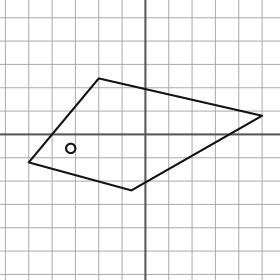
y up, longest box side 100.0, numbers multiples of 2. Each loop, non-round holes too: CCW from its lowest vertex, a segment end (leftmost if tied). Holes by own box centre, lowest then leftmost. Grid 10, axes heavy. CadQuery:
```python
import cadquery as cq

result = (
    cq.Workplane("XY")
    .moveTo(-6.0, -24.0)
    .lineTo(50.0, 8.0)
    .lineTo(-20.0, 24.0)
    .lineTo(-50.0, -12.0)
    .close()
    .moveTo(-32.0, -6.0)
    .circle(2.0)
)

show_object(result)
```